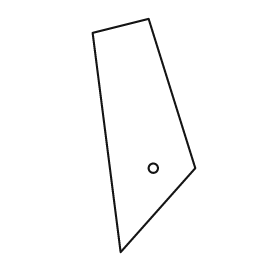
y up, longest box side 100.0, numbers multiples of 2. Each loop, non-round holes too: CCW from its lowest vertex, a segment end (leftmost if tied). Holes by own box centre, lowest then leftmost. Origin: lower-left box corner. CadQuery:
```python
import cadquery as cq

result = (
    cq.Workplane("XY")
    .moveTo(12.0, 0.0)
    .lineTo(44.0, 36.0)
    .lineTo(24.0, 100.0)
    .lineTo(0.0, 94.0)
    .close()
    .moveTo(26.0, 36.0)
    .circle(2.0)
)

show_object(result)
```